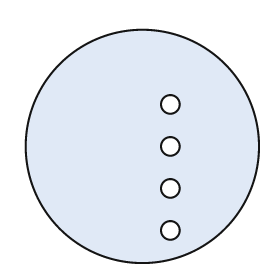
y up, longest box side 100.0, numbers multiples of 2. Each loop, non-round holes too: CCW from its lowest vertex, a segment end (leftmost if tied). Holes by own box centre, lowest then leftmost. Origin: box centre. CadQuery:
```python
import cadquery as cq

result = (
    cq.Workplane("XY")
    .moveTo(0.0, 0.0)
    .circle(50.0)
    .moveTo(12.0, -36.0)
    .circle(4.0)
    .moveTo(12.0, -18.0)
    .circle(4.0)
    .moveTo(12.0, 0.0)
    .circle(4.0)
    .moveTo(12.0, 18.0)
    .circle(4.0)
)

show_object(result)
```